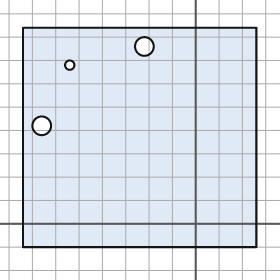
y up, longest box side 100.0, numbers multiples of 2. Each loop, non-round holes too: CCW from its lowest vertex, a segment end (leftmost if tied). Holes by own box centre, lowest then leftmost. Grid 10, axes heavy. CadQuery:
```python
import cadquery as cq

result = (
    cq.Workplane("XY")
    .moveTo(-74.0, -10.0)
    .lineTo(26.0, -10.0)
    .lineTo(26.0, 84.0)
    .lineTo(-74.0, 84.0)
    .close()
    .moveTo(-66.0, 42.0)
    .circle(4.0)
    .moveTo(-54.0, 68.0)
    .circle(2.0)
    .moveTo(-22.0, 76.0)
    .circle(4.0)
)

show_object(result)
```